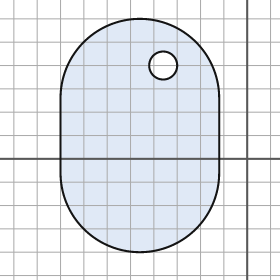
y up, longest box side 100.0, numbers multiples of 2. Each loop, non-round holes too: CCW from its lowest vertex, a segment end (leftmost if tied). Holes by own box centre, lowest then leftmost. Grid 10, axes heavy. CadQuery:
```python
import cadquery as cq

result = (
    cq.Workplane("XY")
    .moveTo(-80.0, -6.0)
    .threePointArc((-46.0, -40.0), (-12.0, -6.0))
    .lineTo(-12.0, 26.0)
    .threePointArc((-46.0, 60.0), (-80.0, 26.0))
    .close()
    .moveTo(-36.0, 40.0)
    .circle(6.0)
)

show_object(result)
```